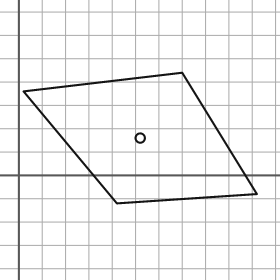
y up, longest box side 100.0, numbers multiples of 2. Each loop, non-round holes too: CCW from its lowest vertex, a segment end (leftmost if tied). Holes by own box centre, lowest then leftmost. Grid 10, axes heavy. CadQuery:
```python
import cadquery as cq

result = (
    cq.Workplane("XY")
    .moveTo(42.0, -12.0)
    .lineTo(102.0, -8.0)
    .lineTo(70.0, 44.0)
    .lineTo(2.0, 36.0)
    .close()
    .moveTo(52.0, 16.0)
    .circle(2.0)
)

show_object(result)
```